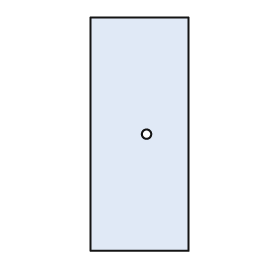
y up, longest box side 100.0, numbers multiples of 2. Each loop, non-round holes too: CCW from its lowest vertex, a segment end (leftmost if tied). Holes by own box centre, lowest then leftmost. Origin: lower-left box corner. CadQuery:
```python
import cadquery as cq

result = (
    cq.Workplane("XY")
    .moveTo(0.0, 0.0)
    .lineTo(42.0, 0.0)
    .lineTo(42.0, 100.0)
    .lineTo(0.0, 100.0)
    .close()
    .moveTo(24.0, 50.0)
    .circle(2.0)
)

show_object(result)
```